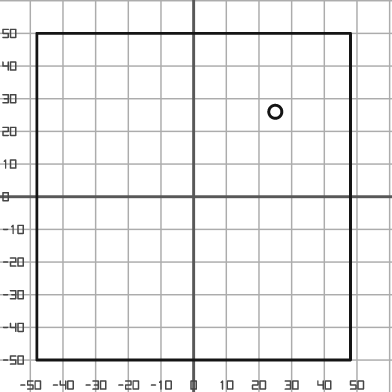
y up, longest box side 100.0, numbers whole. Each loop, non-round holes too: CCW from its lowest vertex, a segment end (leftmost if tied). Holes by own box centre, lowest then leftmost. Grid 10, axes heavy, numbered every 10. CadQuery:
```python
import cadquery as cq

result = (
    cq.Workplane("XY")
    .moveTo(-48.0, -50.0)
    .lineTo(48.0, -50.0)
    .lineTo(48.0, 50.0)
    .lineTo(-48.0, 50.0)
    .close()
    .moveTo(25.0, 26.0)
    .circle(2.0)
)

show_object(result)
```